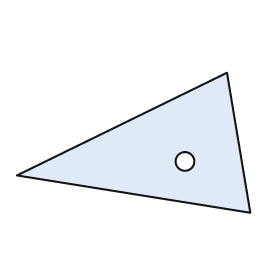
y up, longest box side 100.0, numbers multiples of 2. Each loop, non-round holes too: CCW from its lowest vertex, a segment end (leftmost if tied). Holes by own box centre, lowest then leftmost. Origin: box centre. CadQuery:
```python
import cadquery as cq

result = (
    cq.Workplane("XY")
    .moveTo(50.0, -30.0)
    .lineTo(40.0, 30.0)
    .lineTo(-50.0, -14.0)
    .close()
    .moveTo(22.0, -8.0)
    .circle(4.0)
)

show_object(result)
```